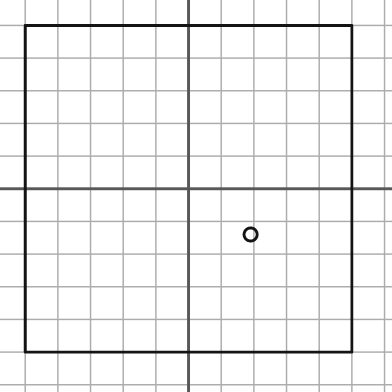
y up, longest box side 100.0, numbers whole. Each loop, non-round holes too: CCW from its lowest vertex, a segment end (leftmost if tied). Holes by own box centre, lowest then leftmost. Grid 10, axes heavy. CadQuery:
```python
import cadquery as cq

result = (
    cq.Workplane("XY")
    .moveTo(-50.0, -50.0)
    .lineTo(50.0, -50.0)
    .lineTo(50.0, 50.0)
    .lineTo(-50.0, 50.0)
    .close()
    .moveTo(19.0, -14.0)
    .circle(2.0)
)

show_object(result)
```